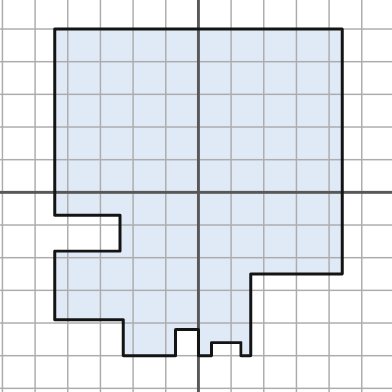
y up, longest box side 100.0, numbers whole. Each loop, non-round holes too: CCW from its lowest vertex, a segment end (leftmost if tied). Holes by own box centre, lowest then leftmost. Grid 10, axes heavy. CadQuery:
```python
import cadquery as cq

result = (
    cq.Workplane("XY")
    .moveTo(-23.0, -50.0)
    .lineTo(-7.0, -50.0)
    .lineTo(-7.0, -42.0)
    .lineTo(0.0, -42.0)
    .lineTo(0.0, -50.0)
    .lineTo(4.0, -50.0)
    .lineTo(4.0, -46.0)
    .lineTo(13.0, -46.0)
    .lineTo(13.0, -50.0)
    .lineTo(16.0, -50.0)
    .lineTo(16.0, -25.0)
    .lineTo(44.0, -25.0)
    .lineTo(44.0, 50.0)
    .lineTo(-44.0, 50.0)
    .lineTo(-44.0, -7.0)
    .lineTo(-24.0, -7.0)
    .lineTo(-24.0, -18.0)
    .lineTo(-44.0, -18.0)
    .lineTo(-44.0, -39.0)
    .lineTo(-23.0, -39.0)
    .close()
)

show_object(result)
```